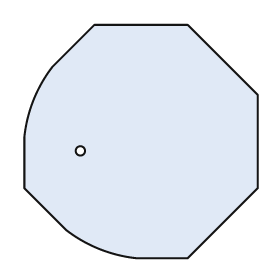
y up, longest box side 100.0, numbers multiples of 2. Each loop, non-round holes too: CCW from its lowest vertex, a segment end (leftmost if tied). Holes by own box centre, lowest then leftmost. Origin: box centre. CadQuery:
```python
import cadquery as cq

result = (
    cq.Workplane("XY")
    .moveTo(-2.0, -50.0)
    .lineTo(20.0, -50.0)
    .lineTo(50.0, -20.0)
    .lineTo(50.0, 20.0)
    .lineTo(20.0, 50.0)
    .lineTo(-20.0, 50.0)
    .lineTo(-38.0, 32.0)
    .threePointArc((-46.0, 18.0), (-50.0, 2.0))
    .lineTo(-50.0, -20.0)
    .lineTo(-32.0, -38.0)
    .threePointArc((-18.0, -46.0), (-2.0, -50.0))
    .close()
    .moveTo(-26.0, -4.0)
    .circle(2.0)
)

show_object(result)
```